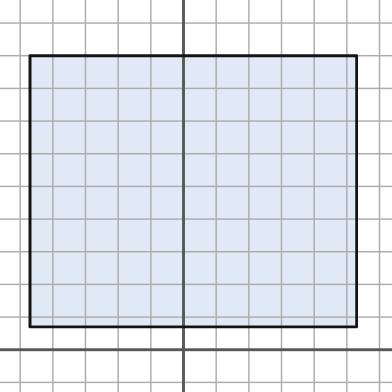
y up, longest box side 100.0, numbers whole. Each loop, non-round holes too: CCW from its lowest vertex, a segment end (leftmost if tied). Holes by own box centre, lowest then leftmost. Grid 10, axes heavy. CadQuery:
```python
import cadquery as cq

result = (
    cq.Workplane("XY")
    .moveTo(-47.0, 7.0)
    .lineTo(53.0, 7.0)
    .lineTo(53.0, 90.0)
    .lineTo(-47.0, 90.0)
    .close()
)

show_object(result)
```